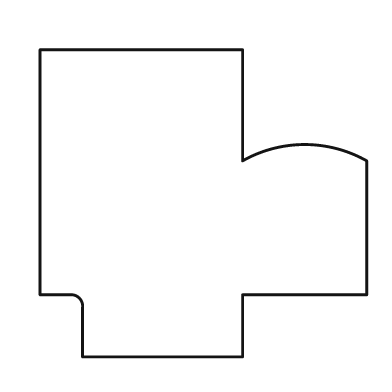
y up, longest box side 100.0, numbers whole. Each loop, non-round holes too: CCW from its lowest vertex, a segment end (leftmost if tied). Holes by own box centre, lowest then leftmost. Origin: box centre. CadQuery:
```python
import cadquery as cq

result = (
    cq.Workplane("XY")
    .moveTo(-37.0, -47.0)
    .lineTo(12.0, -47.0)
    .lineTo(12.0, -28.0)
    .lineTo(50.0, -28.0)
    .lineTo(50.0, 13.0)
    .threePointArc((31.0, 18.0), (12.0, 13.0))
    .lineTo(12.0, 47.0)
    .lineTo(-50.0, 47.0)
    .lineTo(-50.0, -28.0)
    .lineTo(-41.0, -28.0)
    .threePointArc((-38.0, -29.0), (-37.0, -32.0))
    .close()
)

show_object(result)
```